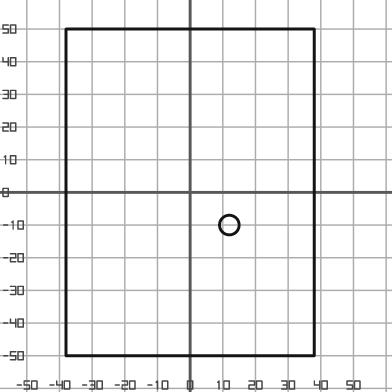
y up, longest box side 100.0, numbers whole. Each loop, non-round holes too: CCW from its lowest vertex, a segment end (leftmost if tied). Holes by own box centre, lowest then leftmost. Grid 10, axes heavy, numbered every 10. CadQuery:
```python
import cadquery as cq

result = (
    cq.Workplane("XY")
    .moveTo(-38.0, -50.0)
    .lineTo(38.0, -50.0)
    .lineTo(38.0, 50.0)
    .lineTo(-38.0, 50.0)
    .close()
    .moveTo(12.0, -10.0)
    .circle(3.0)
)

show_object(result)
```